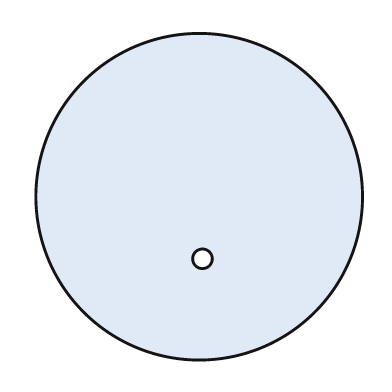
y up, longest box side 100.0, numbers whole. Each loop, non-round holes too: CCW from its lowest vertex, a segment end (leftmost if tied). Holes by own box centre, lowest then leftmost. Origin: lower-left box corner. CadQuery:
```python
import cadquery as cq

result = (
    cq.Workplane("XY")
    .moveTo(50.0, 50.0)
    .circle(50.0)
    .moveTo(51.0, 31.0)
    .circle(3.0)
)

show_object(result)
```